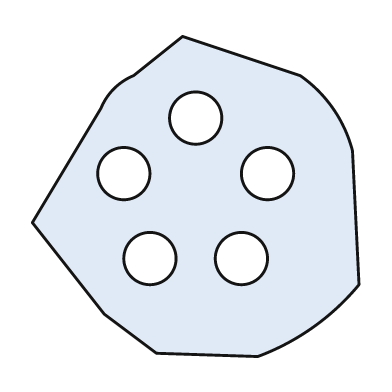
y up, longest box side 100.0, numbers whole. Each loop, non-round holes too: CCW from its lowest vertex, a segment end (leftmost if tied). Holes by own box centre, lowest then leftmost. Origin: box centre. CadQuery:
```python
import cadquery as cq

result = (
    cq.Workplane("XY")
    .moveTo(19.0, -49.0)
    .threePointArc((36.0, -40.0), (50.0, -27.0))
    .lineTo(48.0, 14.0)
    .threePointArc((42.0, 27.0), (32.0, 37.0))
    .lineTo(-4.0, 49.0)
    .lineTo(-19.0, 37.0)
    .threePointArc((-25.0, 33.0), (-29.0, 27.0))
    .lineTo(-50.0, -8.0)
    .lineTo(-28.0, -36.0)
    .lineTo(-12.0, -48.0)
    .close()
    .moveTo(-14.0, -19.0)
    .circle(8.0)
    .moveTo(14.0, -19.0)
    .circle(8.0)
    .moveTo(-22.0, 7.0)
    .circle(8.0)
    .moveTo(22.0, 7.0)
    .circle(8.0)
    .moveTo(0.0, 24.0)
    .circle(8.0)
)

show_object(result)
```